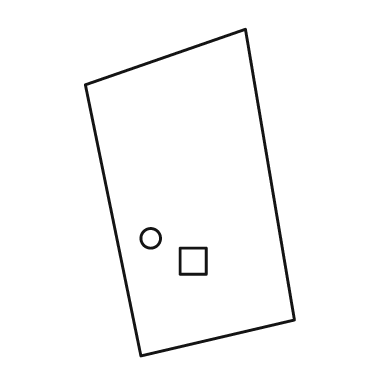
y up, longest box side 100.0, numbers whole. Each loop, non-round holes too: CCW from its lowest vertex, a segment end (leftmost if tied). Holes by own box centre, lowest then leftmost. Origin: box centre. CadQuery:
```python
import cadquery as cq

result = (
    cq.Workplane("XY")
    .moveTo(-15.0, -50.0)
    .lineTo(32.0, -39.0)
    .lineTo(17.0, 50.0)
    .lineTo(-32.0, 33.0)
    .close()
    .moveTo(-3.0, -25.0)
    .lineTo(5.0, -25.0)
    .lineTo(5.0, -17.0)
    .lineTo(-3.0, -17.0)
    .close()
    .moveTo(-12.0, -14.0)
    .circle(3.0)
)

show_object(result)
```